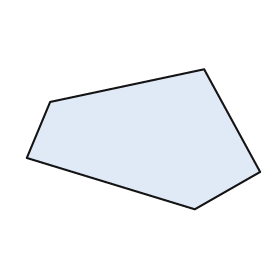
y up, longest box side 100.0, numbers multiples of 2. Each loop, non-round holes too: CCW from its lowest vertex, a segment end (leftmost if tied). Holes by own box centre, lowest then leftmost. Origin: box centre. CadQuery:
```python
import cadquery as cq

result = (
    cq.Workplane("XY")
    .moveTo(22.0, -30.0)
    .lineTo(50.0, -14.0)
    .lineTo(26.0, 30.0)
    .lineTo(-40.0, 16.0)
    .lineTo(-50.0, -8.0)
    .close()
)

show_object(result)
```